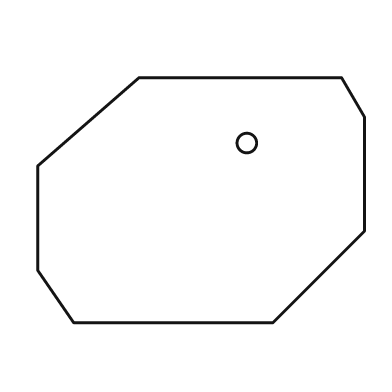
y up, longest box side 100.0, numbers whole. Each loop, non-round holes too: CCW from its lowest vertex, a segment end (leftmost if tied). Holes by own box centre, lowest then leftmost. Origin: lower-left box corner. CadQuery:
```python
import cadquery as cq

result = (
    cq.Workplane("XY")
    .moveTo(11.0, 0.0)
    .lineTo(72.0, 0.0)
    .lineTo(100.0, 28.0)
    .lineTo(100.0, 63.0)
    .lineTo(93.0, 75.0)
    .lineTo(31.0, 75.0)
    .lineTo(0.0, 48.0)
    .lineTo(0.0, 16.0)
    .close()
    .moveTo(64.0, 55.0)
    .circle(3.0)
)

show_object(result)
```